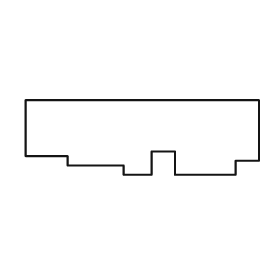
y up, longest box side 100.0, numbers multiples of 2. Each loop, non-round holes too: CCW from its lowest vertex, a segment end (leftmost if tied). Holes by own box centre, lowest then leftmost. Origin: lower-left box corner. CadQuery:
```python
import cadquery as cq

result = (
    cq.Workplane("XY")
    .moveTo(42.0, 0.0)
    .lineTo(54.0, 0.0)
    .lineTo(54.0, 10.0)
    .lineTo(64.0, 10.0)
    .lineTo(64.0, 0.0)
    .lineTo(90.0, 0.0)
    .lineTo(90.0, 6.0)
    .lineTo(100.0, 6.0)
    .lineTo(100.0, 32.0)
    .lineTo(0.0, 32.0)
    .lineTo(0.0, 8.0)
    .lineTo(18.0, 8.0)
    .lineTo(18.0, 4.0)
    .lineTo(42.0, 4.0)
    .close()
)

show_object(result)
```